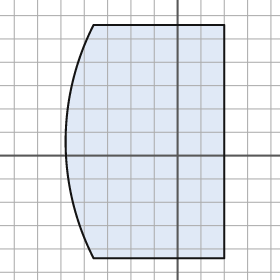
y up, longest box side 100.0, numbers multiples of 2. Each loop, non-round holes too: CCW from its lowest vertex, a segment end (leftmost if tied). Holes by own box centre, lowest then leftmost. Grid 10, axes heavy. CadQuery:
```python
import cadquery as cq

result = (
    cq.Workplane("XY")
    .moveTo(-36.0, -44.0)
    .lineTo(20.0, -44.0)
    .lineTo(20.0, 56.0)
    .lineTo(-36.0, 56.0)
    .threePointArc((-48.0, 6.0), (-36.0, -44.0))
    .close()
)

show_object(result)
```